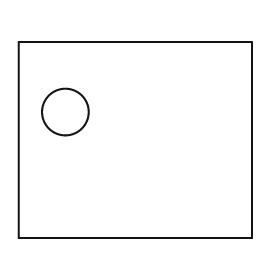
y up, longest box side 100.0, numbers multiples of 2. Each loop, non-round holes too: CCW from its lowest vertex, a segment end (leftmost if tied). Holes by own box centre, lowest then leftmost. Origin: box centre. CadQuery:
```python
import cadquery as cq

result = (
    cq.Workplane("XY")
    .moveTo(-50.0, -42.0)
    .lineTo(50.0, -42.0)
    .lineTo(50.0, 42.0)
    .lineTo(-50.0, 42.0)
    .close()
    .moveTo(-30.0, 12.0)
    .circle(10.0)
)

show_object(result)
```